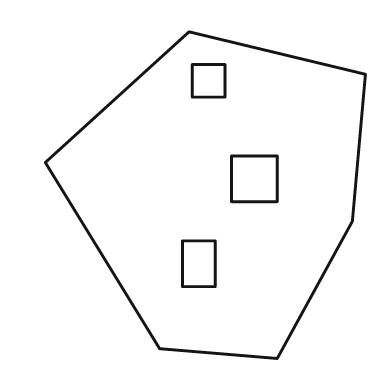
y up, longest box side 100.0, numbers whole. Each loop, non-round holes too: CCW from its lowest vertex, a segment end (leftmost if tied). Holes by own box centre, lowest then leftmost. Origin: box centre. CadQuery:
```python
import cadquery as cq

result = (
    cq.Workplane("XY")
    .moveTo(22.0, -50.0)
    .lineTo(45.0, -8.0)
    .lineTo(49.0, 37.0)
    .lineTo(-5.0, 50.0)
    .lineTo(-49.0, 10.0)
    .lineTo(-14.0, -47.0)
    .close()
    .moveTo(-7.0, -28.0)
    .lineTo(3.0, -28.0)
    .lineTo(3.0, -14.0)
    .lineTo(-7.0, -14.0)
    .close()
    .moveTo(8.0, -2.0)
    .lineTo(22.0, -2.0)
    .lineTo(22.0, 12.0)
    .lineTo(8.0, 12.0)
    .close()
    .moveTo(-4.0, 30.0)
    .lineTo(6.0, 30.0)
    .lineTo(6.0, 40.0)
    .lineTo(-4.0, 40.0)
    .close()
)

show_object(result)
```